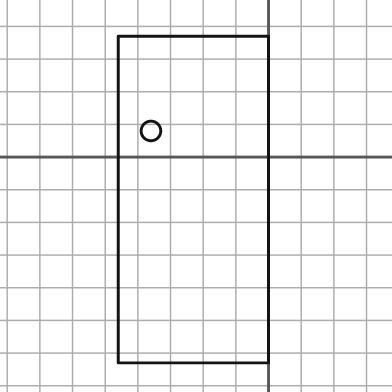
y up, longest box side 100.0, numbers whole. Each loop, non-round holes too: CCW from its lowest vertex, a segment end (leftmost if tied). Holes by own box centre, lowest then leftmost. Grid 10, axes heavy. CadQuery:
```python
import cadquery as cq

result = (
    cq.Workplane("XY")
    .moveTo(-46.0, -63.0)
    .lineTo(0.0, -63.0)
    .lineTo(0.0, 37.0)
    .lineTo(-46.0, 37.0)
    .close()
    .moveTo(-36.0, 8.0)
    .circle(3.0)
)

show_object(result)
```